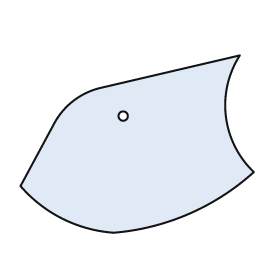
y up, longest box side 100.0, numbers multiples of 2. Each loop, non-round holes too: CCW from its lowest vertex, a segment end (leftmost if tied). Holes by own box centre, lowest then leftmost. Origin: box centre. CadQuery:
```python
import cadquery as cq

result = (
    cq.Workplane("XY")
    .moveTo(-10.0, -38.0)
    .threePointArc((22.0, -30.0), (50.0, -12.0))
    .threePointArc((38.0, 12.0), (44.0, 38.0))
    .lineTo(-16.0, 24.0)
    .threePointArc((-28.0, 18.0), (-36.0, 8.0))
    .lineTo(-50.0, -18.0)
    .threePointArc((-32.0, -32.0), (-10.0, -38.0))
    .close()
    .moveTo(-6.0, 12.0)
    .circle(2.0)
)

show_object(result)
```